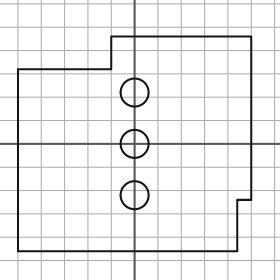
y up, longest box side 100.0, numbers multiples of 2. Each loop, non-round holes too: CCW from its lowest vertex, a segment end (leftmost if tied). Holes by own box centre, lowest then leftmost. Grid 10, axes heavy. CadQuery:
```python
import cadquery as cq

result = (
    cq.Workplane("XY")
    .moveTo(-50.0, -46.0)
    .lineTo(44.0, -46.0)
    .lineTo(44.0, -24.0)
    .lineTo(50.0, -24.0)
    .lineTo(50.0, 46.0)
    .lineTo(-10.0, 46.0)
    .lineTo(-10.0, 32.0)
    .lineTo(-50.0, 32.0)
    .close()
    .moveTo(0.0, -22.0)
    .circle(6.0)
    .moveTo(0.0, 0.0)
    .circle(6.0)
    .moveTo(0.0, 22.0)
    .circle(6.0)
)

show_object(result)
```